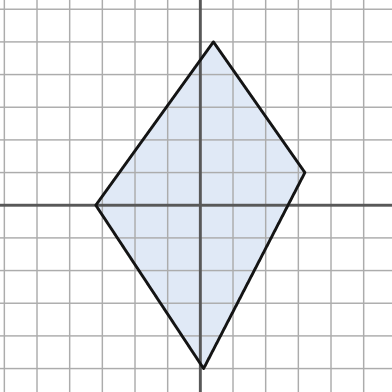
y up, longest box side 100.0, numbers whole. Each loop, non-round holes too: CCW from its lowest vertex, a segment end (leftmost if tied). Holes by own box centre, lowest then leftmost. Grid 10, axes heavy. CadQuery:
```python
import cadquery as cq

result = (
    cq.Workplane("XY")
    .moveTo(1.0, -50.0)
    .lineTo(32.0, 10.0)
    .lineTo(4.0, 50.0)
    .lineTo(-32.0, 0.0)
    .close()
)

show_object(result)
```